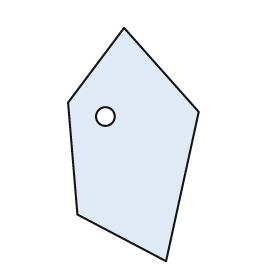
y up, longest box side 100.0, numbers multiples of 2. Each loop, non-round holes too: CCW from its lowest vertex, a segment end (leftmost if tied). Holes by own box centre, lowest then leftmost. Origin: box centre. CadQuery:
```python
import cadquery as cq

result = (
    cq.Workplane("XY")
    .moveTo(14.0, -50.0)
    .lineTo(28.0, 14.0)
    .lineTo(-4.0, 50.0)
    .lineTo(-28.0, 18.0)
    .lineTo(-24.0, -30.0)
    .close()
    .moveTo(-12.0, 12.0)
    .circle(4.0)
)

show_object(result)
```